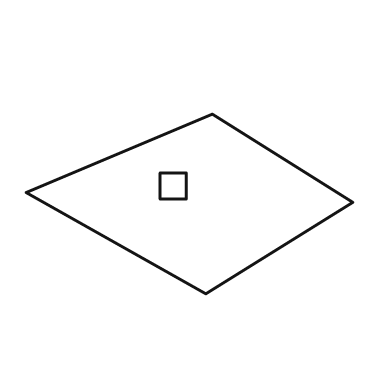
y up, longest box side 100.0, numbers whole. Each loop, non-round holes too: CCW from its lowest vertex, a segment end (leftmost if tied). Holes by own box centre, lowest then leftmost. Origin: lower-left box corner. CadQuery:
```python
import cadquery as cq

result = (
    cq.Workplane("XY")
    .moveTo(55.0, 0.0)
    .lineTo(100.0, 28.0)
    .lineTo(57.0, 55.0)
    .lineTo(0.0, 31.0)
    .close()
    .moveTo(41.0, 29.0)
    .lineTo(49.0, 29.0)
    .lineTo(49.0, 37.0)
    .lineTo(41.0, 37.0)
    .close()
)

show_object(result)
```